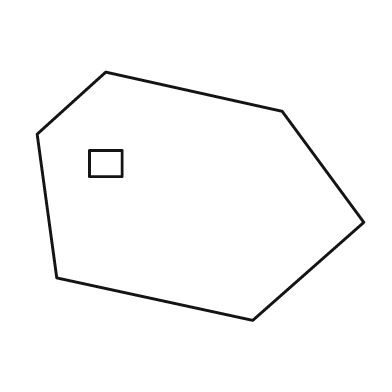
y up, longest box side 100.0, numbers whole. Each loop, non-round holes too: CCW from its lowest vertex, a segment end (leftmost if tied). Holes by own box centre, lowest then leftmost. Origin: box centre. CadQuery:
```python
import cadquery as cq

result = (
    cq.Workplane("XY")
    .moveTo(16.0, -38.0)
    .lineTo(50.0, -8.0)
    .lineTo(25.0, 26.0)
    .lineTo(-29.0, 38.0)
    .lineTo(-50.0, 19.0)
    .lineTo(-44.0, -25.0)
    .close()
    .moveTo(-34.0, 6.0)
    .lineTo(-24.0, 6.0)
    .lineTo(-24.0, 14.0)
    .lineTo(-34.0, 14.0)
    .close()
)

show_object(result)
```